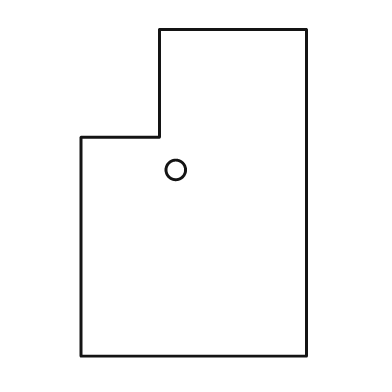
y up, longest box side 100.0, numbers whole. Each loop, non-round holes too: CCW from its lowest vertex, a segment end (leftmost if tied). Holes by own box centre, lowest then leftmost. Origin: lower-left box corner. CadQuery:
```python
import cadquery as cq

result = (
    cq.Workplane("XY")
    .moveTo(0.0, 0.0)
    .lineTo(69.0, 0.0)
    .lineTo(69.0, 100.0)
    .lineTo(24.0, 100.0)
    .lineTo(24.0, 67.0)
    .lineTo(0.0, 67.0)
    .close()
    .moveTo(29.0, 57.0)
    .circle(3.0)
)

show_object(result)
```